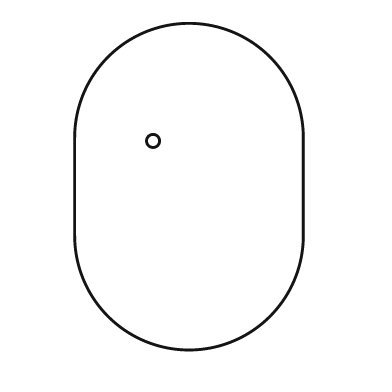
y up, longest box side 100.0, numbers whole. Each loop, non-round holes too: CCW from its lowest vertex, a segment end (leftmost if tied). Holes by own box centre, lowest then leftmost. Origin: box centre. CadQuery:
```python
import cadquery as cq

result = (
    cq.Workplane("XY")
    .moveTo(-35.0, -15.0)
    .threePointArc((0.0, -50.0), (35.0, -15.0))
    .lineTo(35.0, 15.0)
    .threePointArc((0.0, 50.0), (-35.0, 15.0))
    .close()
    .moveTo(-11.0, 14.0)
    .circle(2.0)
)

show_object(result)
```